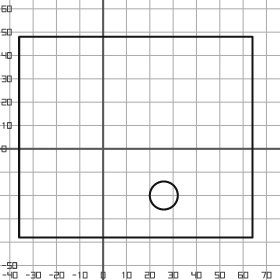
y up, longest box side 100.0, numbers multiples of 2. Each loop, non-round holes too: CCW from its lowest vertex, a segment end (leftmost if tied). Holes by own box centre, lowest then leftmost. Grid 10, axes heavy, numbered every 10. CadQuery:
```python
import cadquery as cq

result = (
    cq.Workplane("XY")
    .moveTo(-36.0, -38.0)
    .lineTo(64.0, -38.0)
    .lineTo(64.0, 48.0)
    .lineTo(-36.0, 48.0)
    .close()
    .moveTo(26.0, -20.0)
    .circle(6.0)
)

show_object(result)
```